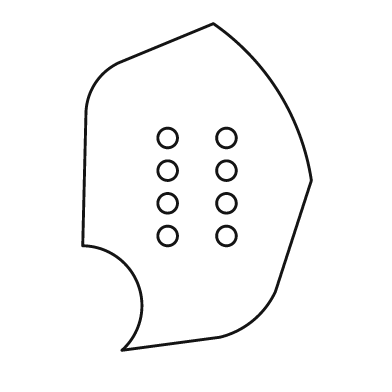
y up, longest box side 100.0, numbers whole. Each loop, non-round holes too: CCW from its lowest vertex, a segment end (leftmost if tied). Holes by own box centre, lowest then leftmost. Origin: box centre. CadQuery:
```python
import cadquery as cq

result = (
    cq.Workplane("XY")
    .moveTo(-23.0, -50.0)
    .lineTo(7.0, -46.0)
    .threePointArc((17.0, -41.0), (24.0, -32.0))
    .lineTo(35.0, 2.0)
    .threePointArc((25.0, 29.0), (5.0, 50.0))
    .lineTo(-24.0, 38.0)
    .threePointArc((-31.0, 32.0), (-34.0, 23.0))
    .lineTo(-35.0, -18.0)
    .threePointArc((-18.0, -30.0), (-23.0, -50.0))
    .close()
    .moveTo(-9.0, -15.0)
    .circle(3.0)
    .moveTo(9.0, -15.0)
    .circle(3.0)
    .moveTo(-9.0, -5.0)
    .circle(3.0)
    .moveTo(9.0, -5.0)
    .circle(3.0)
    .moveTo(-9.0, 5.0)
    .circle(3.0)
    .moveTo(9.0, 5.0)
    .circle(3.0)
    .moveTo(-9.0, 15.0)
    .circle(3.0)
    .moveTo(9.0, 15.0)
    .circle(3.0)
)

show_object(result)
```